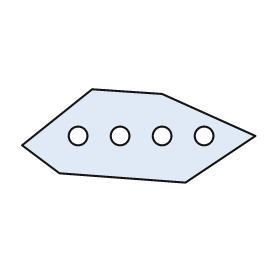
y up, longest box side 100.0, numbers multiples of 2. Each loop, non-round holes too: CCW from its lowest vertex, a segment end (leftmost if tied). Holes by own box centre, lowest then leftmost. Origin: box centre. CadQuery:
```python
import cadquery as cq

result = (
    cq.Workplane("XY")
    .moveTo(20.0, -20.0)
    .lineTo(50.0, 0.0)
    .lineTo(10.0, 18.0)
    .lineTo(-20.0, 20.0)
    .lineTo(-50.0, -4.0)
    .lineTo(-34.0, -16.0)
    .close()
    .moveTo(-26.0, 0.0)
    .circle(4.0)
    .moveTo(-8.0, 0.0)
    .circle(4.0)
    .moveTo(10.0, 0.0)
    .circle(4.0)
    .moveTo(28.0, 0.0)
    .circle(4.0)
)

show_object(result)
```